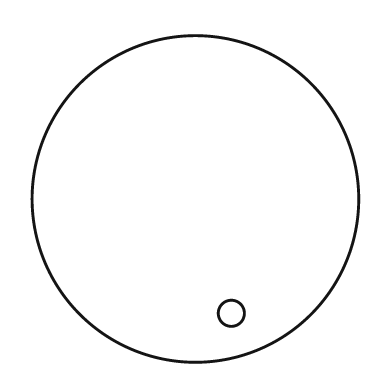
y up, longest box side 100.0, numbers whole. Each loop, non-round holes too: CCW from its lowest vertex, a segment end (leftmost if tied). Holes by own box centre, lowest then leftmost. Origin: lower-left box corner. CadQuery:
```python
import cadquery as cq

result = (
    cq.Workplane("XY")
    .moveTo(50.0, 50.0)
    .circle(50.0)
    .moveTo(61.0, 15.0)
    .circle(4.0)
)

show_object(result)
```